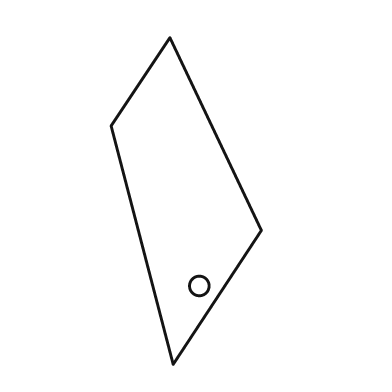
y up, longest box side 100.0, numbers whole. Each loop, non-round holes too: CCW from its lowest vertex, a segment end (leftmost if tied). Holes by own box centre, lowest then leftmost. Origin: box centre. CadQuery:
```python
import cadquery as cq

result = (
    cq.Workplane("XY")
    .moveTo(-4.0, -50.0)
    .lineTo(23.0, -9.0)
    .lineTo(-5.0, 50.0)
    .lineTo(-23.0, 23.0)
    .close()
    .moveTo(4.0, -26.0)
    .circle(3.0)
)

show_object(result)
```